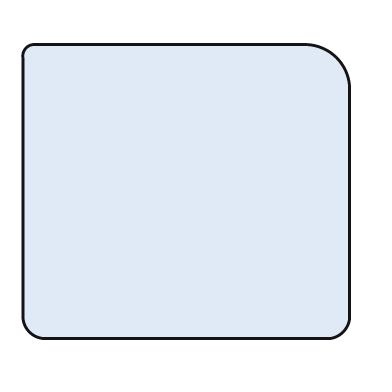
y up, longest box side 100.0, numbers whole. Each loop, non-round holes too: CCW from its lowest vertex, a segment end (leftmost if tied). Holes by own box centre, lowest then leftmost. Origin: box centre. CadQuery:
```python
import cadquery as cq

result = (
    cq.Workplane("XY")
    .moveTo(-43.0, -45.0)
    .lineTo(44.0, -45.0)
    .threePointArc((48.0, -43.0), (50.0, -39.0))
    .lineTo(50.0, 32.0)
    .threePointArc((46.0, 41.0), (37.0, 45.0))
    .lineTo(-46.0, 45.0)
    .threePointArc((-49.0, 44.0), (-50.0, 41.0))
    .lineTo(-50.0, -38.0)
    .threePointArc((-48.0, -43.0), (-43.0, -45.0))
    .close()
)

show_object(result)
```